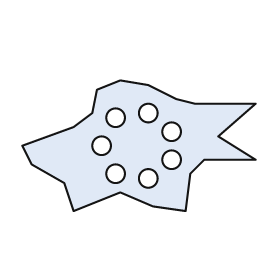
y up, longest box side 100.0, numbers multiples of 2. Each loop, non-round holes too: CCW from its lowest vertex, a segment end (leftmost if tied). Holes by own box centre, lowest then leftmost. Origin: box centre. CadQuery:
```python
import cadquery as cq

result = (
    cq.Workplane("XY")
    .moveTo(-28.0, -28.0)
    .lineTo(-8.0, -20.0)
    .lineTo(6.0, -26.0)
    .lineTo(20.0, -28.0)
    .lineTo(22.0, -12.0)
    .lineTo(28.0, -6.0)
    .lineTo(50.0, -6.0)
    .lineTo(34.0, 4.0)
    .lineTo(50.0, 18.0)
    .lineTo(24.0, 18.0)
    .lineTo(16.0, 20.0)
    .lineTo(4.0, 26.0)
    .lineTo(-8.0, 28.0)
    .lineTo(-18.0, 24.0)
    .lineTo(-20.0, 14.0)
    .lineTo(-28.0, 8.0)
    .lineTo(-50.0, 0.0)
    .lineTo(-46.0, -8.0)
    .lineTo(-32.0, -16.0)
    .close()
    .moveTo(4.0, -14.0)
    .circle(4.0)
    .moveTo(-10.0, -12.0)
    .circle(4.0)
    .moveTo(14.0, -6.0)
    .circle(4.0)
    .moveTo(-16.0, 0.0)
    .circle(4.0)
    .moveTo(14.0, 6.0)
    .circle(4.0)
    .moveTo(-10.0, 12.0)
    .circle(4.0)
    .moveTo(4.0, 14.0)
    .circle(4.0)
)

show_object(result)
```